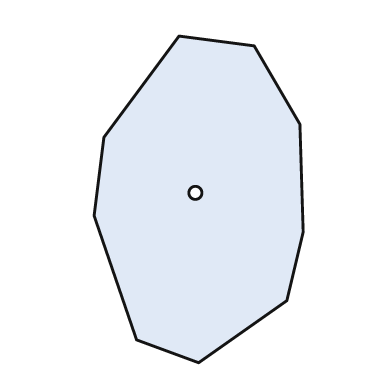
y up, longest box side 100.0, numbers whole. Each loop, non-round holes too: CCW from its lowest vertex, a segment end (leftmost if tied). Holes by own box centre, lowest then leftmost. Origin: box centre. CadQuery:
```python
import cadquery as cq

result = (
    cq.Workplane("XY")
    .moveTo(0.0, -50.0)
    .lineTo(27.0, -31.0)
    .lineTo(32.0, -10.0)
    .lineTo(31.0, 23.0)
    .lineTo(17.0, 47.0)
    .lineTo(-6.0, 50.0)
    .lineTo(-29.0, 19.0)
    .lineTo(-32.0, -5.0)
    .lineTo(-19.0, -43.0)
    .close()
    .moveTo(-1.0, 2.0)
    .circle(2.0)
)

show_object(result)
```